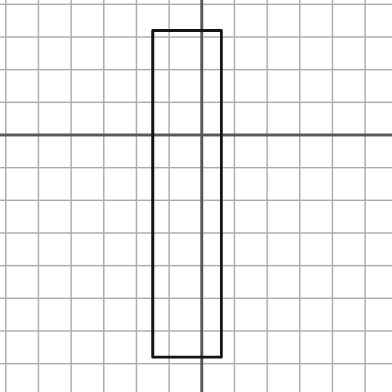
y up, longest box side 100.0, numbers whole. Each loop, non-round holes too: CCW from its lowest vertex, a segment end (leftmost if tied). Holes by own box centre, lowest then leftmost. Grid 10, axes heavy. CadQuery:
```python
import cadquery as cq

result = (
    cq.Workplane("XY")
    .moveTo(-15.0, -68.0)
    .lineTo(6.0, -68.0)
    .lineTo(6.0, 32.0)
    .lineTo(-15.0, 32.0)
    .close()
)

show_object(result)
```